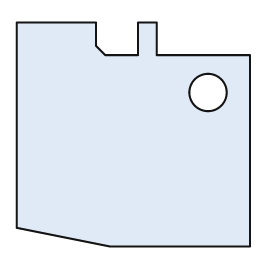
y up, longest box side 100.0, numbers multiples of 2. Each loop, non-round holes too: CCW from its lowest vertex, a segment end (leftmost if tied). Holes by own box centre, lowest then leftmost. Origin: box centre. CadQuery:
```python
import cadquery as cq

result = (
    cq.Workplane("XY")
    .moveTo(-10.0, -48.0)
    .lineTo(50.0, -48.0)
    .lineTo(50.0, 34.0)
    .lineTo(10.0, 34.0)
    .lineTo(10.0, 48.0)
    .lineTo(2.0, 48.0)
    .lineTo(2.0, 34.0)
    .lineTo(-12.0, 34.0)
    .lineTo(-16.0, 38.0)
    .lineTo(-16.0, 48.0)
    .lineTo(-50.0, 48.0)
    .lineTo(-50.0, -40.0)
    .close()
    .moveTo(32.0, 18.0)
    .circle(8.0)
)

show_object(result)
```